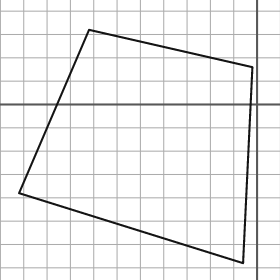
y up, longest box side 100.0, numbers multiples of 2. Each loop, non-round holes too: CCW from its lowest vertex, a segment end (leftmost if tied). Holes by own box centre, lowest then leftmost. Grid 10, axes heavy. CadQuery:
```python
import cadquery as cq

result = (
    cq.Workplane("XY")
    .moveTo(-6.0, -68.0)
    .lineTo(-2.0, 16.0)
    .lineTo(-72.0, 32.0)
    .lineTo(-102.0, -38.0)
    .close()
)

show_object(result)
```